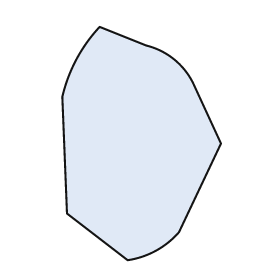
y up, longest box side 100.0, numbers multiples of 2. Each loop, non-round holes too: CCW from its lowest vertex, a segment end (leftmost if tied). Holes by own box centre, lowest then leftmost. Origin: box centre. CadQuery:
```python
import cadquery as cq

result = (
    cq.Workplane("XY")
    .moveTo(-6.0, -50.0)
    .threePointArc((6.0, -46.0), (16.0, -38.0))
    .lineTo(34.0, 0.0)
    .lineTo(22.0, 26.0)
    .threePointArc((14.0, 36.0), (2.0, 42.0))
    .lineTo(-18.0, 50.0)
    .threePointArc((-28.0, 36.0), (-34.0, 20.0))
    .lineTo(-32.0, -30.0)
    .close()
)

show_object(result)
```